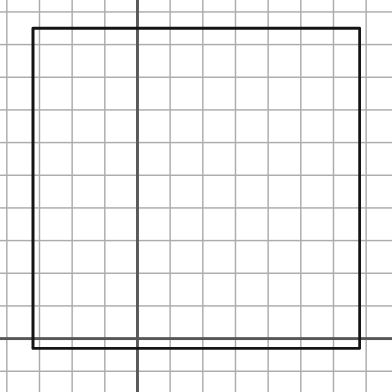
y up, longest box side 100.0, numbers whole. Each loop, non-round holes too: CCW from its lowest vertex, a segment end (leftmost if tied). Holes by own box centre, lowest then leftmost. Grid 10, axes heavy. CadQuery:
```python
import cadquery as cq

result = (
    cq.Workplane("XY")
    .moveTo(-32.0, -3.0)
    .lineTo(68.0, -3.0)
    .lineTo(68.0, 95.0)
    .lineTo(-32.0, 95.0)
    .close()
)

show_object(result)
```